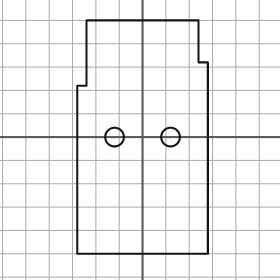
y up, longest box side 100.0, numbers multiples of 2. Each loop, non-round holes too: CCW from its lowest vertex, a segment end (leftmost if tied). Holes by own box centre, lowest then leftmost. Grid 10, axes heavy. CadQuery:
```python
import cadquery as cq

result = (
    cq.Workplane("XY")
    .moveTo(-28.0, -50.0)
    .lineTo(28.0, -50.0)
    .lineTo(28.0, 32.0)
    .lineTo(24.0, 32.0)
    .lineTo(24.0, 50.0)
    .lineTo(-24.0, 50.0)
    .lineTo(-24.0, 22.0)
    .lineTo(-28.0, 22.0)
    .close()
    .moveTo(-12.0, 0.0)
    .circle(4.0)
    .moveTo(12.0, 0.0)
    .circle(4.0)
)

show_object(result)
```